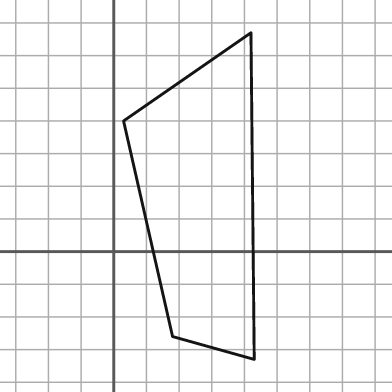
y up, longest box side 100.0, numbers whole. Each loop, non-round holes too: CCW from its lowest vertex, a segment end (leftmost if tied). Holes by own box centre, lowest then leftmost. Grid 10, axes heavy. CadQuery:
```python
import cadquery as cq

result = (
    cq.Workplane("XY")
    .moveTo(43.0, -33.0)
    .lineTo(42.0, 67.0)
    .lineTo(3.0, 40.0)
    .lineTo(18.0, -26.0)
    .close()
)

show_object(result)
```